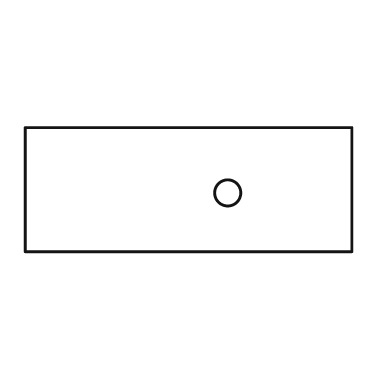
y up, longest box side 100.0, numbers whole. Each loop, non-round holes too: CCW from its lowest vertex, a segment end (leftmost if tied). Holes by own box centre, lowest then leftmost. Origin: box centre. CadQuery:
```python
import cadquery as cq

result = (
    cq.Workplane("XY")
    .moveTo(-50.0, -19.0)
    .lineTo(50.0, -19.0)
    .lineTo(50.0, 19.0)
    .lineTo(-50.0, 19.0)
    .close()
    .moveTo(12.0, -1.0)
    .circle(4.0)
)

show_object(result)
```